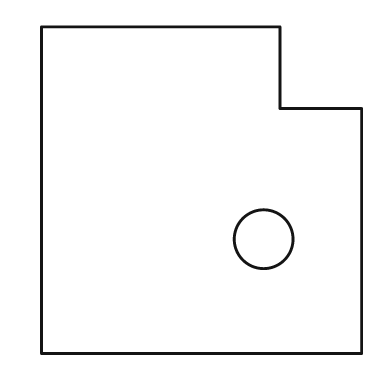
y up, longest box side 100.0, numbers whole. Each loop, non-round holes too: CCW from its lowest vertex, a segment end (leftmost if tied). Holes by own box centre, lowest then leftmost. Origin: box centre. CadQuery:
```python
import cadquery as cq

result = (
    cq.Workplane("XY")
    .moveTo(-49.0, -50.0)
    .lineTo(49.0, -50.0)
    .lineTo(49.0, 25.0)
    .lineTo(24.0, 25.0)
    .lineTo(24.0, 50.0)
    .lineTo(-49.0, 50.0)
    .close()
    .moveTo(19.0, -15.0)
    .circle(9.0)
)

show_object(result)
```